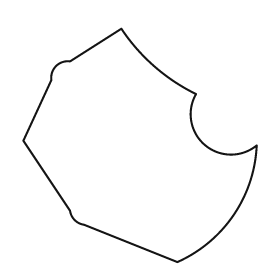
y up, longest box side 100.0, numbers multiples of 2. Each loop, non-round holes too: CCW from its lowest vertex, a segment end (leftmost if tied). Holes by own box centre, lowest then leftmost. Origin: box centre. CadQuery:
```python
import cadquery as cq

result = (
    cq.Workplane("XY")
    .moveTo(16.0, -50.0)
    .threePointArc((40.0, -30.0), (50.0, 0.0))
    .threePointArc((28.0, 0.0), (24.0, 22.0))
    .threePointArc((6.0, 34.0), (-8.0, 50.0))
    .lineTo(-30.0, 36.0)
    .threePointArc((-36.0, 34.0), (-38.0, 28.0))
    .lineTo(-50.0, 2.0)
    .lineTo(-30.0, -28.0)
    .threePointArc((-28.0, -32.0), (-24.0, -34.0))
    .close()
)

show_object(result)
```